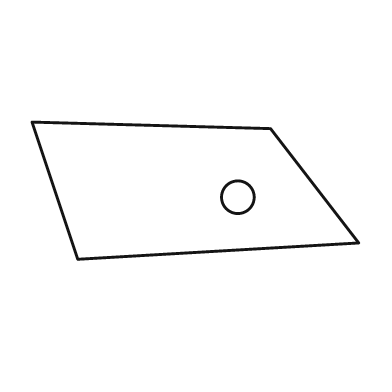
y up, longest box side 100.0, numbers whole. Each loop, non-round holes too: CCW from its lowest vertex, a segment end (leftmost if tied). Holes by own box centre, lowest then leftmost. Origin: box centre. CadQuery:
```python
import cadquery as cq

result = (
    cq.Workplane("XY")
    .moveTo(-36.0, -21.0)
    .lineTo(50.0, -16.0)
    .lineTo(23.0, 19.0)
    .lineTo(-50.0, 21.0)
    .close()
    .moveTo(13.0, -2.0)
    .circle(5.0)
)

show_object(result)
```